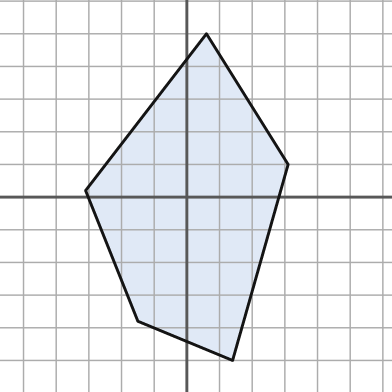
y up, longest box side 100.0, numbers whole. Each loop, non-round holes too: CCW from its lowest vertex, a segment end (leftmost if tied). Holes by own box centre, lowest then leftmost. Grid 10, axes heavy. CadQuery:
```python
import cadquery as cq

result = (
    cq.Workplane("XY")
    .moveTo(14.0, -50.0)
    .lineTo(31.0, 10.0)
    .lineTo(6.0, 50.0)
    .lineTo(-31.0, 2.0)
    .lineTo(-15.0, -38.0)
    .close()
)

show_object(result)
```